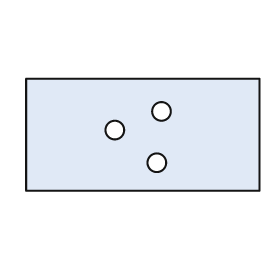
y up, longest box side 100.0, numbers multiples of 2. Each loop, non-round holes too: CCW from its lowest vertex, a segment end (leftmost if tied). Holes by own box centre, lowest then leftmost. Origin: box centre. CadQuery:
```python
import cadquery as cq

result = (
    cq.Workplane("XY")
    .moveTo(-50.0, -24.0)
    .lineTo(50.0, -24.0)
    .lineTo(50.0, 24.0)
    .lineTo(-50.0, 24.0)
    .close()
    .moveTo(6.0, -12.0)
    .circle(4.0)
    .moveTo(-12.0, 2.0)
    .circle(4.0)
    .moveTo(8.0, 10.0)
    .circle(4.0)
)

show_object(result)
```